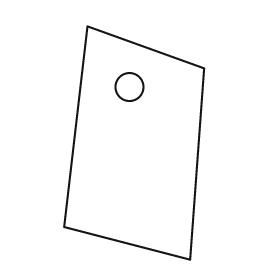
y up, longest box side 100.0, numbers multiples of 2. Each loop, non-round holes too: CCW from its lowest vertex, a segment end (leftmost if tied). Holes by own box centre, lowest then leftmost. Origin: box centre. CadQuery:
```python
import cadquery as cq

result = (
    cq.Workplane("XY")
    .moveTo(24.0, -50.0)
    .lineTo(30.0, 32.0)
    .lineTo(-20.0, 50.0)
    .lineTo(-30.0, -36.0)
    .close()
    .moveTo(-2.0, 24.0)
    .circle(6.0)
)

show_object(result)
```